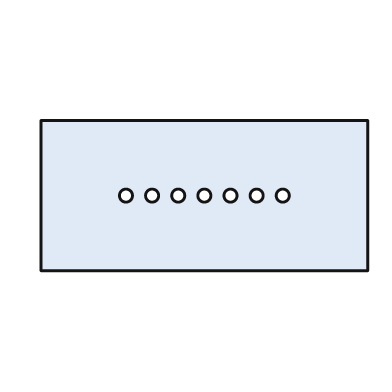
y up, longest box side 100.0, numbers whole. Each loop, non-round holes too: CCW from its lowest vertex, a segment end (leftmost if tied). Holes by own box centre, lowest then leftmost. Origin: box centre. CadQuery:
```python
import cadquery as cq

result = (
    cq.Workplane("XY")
    .moveTo(-50.0, -23.0)
    .lineTo(50.0, -23.0)
    .lineTo(50.0, 23.0)
    .lineTo(-50.0, 23.0)
    .close()
    .moveTo(-24.0, 0.0)
    .circle(2.0)
    .moveTo(-16.0, 0.0)
    .circle(2.0)
    .moveTo(-8.0, 0.0)
    .circle(2.0)
    .moveTo(0.0, 0.0)
    .circle(2.0)
    .moveTo(8.0, 0.0)
    .circle(2.0)
    .moveTo(16.0, 0.0)
    .circle(2.0)
    .moveTo(24.0, 0.0)
    .circle(2.0)
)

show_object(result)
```